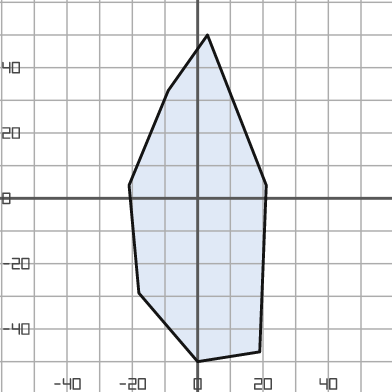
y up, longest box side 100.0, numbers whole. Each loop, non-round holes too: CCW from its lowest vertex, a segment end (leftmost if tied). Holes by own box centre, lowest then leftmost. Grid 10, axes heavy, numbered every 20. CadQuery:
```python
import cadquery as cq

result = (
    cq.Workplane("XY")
    .moveTo(0.0, -50.0)
    .lineTo(19.0, -47.0)
    .lineTo(21.0, 4.0)
    .lineTo(3.0, 50.0)
    .lineTo(-9.0, 33.0)
    .lineTo(-21.0, 4.0)
    .lineTo(-18.0, -29.0)
    .close()
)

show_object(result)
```